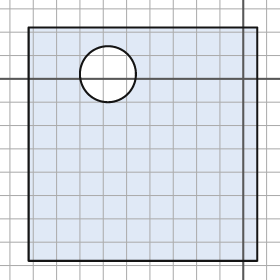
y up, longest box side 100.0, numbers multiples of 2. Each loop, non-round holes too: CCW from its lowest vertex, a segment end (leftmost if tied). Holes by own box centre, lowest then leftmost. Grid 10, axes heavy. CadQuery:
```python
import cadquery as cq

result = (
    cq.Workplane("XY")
    .moveTo(-92.0, -78.0)
    .lineTo(6.0, -78.0)
    .lineTo(6.0, 22.0)
    .lineTo(-92.0, 22.0)
    .close()
    .moveTo(-58.0, 2.0)
    .circle(12.0)
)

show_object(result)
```